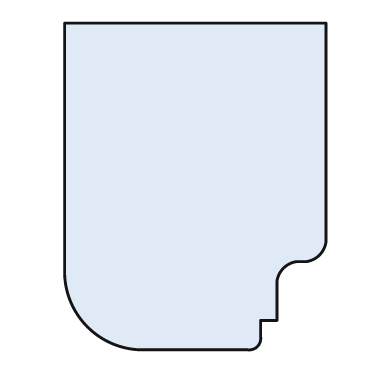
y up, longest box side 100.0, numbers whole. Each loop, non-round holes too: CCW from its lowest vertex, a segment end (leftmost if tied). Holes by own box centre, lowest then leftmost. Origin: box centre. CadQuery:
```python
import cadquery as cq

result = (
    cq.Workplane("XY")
    .moveTo(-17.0, -50.0)
    .lineTo(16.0, -50.0)
    .threePointArc((19.0, -49.0), (20.0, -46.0))
    .lineTo(20.0, -41.0)
    .lineTo(25.0, -41.0)
    .lineTo(25.0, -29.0)
    .threePointArc((27.0, -25.0), (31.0, -23.0))
    .lineTo(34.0, -23.0)
    .threePointArc((38.0, -21.0), (40.0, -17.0))
    .lineTo(40.0, 50.0)
    .lineTo(-40.0, 50.0)
    .lineTo(-40.0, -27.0)
    .threePointArc((-33.0, -43.0), (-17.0, -50.0))
    .close()
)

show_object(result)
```